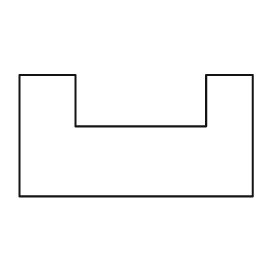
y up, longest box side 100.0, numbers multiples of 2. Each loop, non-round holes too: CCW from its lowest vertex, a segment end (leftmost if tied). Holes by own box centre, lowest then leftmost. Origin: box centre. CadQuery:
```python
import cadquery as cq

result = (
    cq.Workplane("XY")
    .moveTo(-50.0, -26.0)
    .lineTo(50.0, -26.0)
    .lineTo(50.0, 26.0)
    .lineTo(30.0, 26.0)
    .lineTo(30.0, 4.0)
    .lineTo(-26.0, 4.0)
    .lineTo(-26.0, 26.0)
    .lineTo(-50.0, 26.0)
    .close()
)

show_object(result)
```